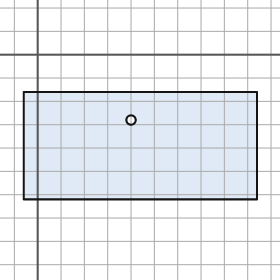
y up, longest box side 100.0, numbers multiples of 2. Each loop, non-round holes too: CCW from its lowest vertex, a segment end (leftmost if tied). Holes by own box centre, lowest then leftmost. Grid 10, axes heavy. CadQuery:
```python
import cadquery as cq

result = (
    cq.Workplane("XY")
    .moveTo(-6.0, -62.0)
    .lineTo(94.0, -62.0)
    .lineTo(94.0, -16.0)
    .lineTo(-6.0, -16.0)
    .close()
    .moveTo(40.0, -28.0)
    .circle(2.0)
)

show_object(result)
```